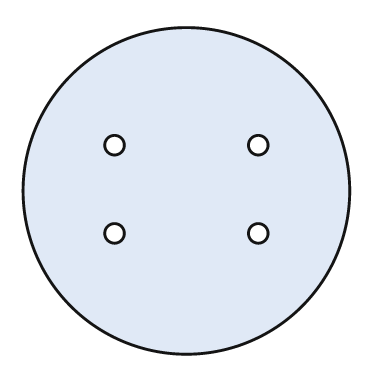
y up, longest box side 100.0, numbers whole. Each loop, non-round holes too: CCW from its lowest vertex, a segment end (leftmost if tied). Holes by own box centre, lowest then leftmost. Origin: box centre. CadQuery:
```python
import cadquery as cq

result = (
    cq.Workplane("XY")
    .moveTo(0.0, 0.0)
    .circle(50.0)
    .moveTo(-22.0, -13.0)
    .circle(3.0)
    .moveTo(22.0, -13.0)
    .circle(3.0)
    .moveTo(-22.0, 14.0)
    .circle(3.0)
    .moveTo(22.0, 14.0)
    .circle(3.0)
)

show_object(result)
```